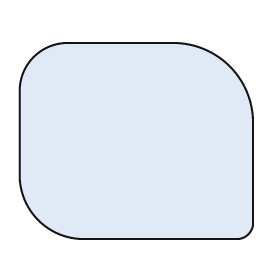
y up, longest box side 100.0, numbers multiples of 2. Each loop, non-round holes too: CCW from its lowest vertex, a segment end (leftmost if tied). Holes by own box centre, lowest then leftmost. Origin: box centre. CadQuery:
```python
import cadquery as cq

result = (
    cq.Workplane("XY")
    .moveTo(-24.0, -42.0)
    .lineTo(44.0, -42.0)
    .threePointArc((48.0, -40.0), (50.0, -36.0))
    .lineTo(50.0, 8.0)
    .threePointArc((40.0, 32.0), (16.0, 42.0))
    .lineTo(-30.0, 42.0)
    .threePointArc((-44.0, 36.0), (-50.0, 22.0))
    .lineTo(-50.0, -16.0)
    .threePointArc((-42.0, -34.0), (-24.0, -42.0))
    .close()
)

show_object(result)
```